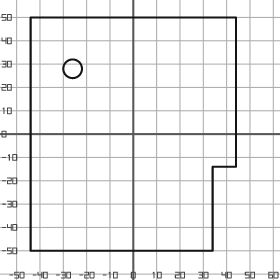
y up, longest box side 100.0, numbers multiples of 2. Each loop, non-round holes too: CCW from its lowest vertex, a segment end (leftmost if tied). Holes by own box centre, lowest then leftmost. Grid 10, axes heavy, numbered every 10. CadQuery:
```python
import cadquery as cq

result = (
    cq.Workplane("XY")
    .moveTo(-44.0, -50.0)
    .lineTo(34.0, -50.0)
    .lineTo(34.0, -14.0)
    .lineTo(44.0, -14.0)
    .lineTo(44.0, 50.0)
    .lineTo(-44.0, 50.0)
    .close()
    .moveTo(-26.0, 28.0)
    .circle(4.0)
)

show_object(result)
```